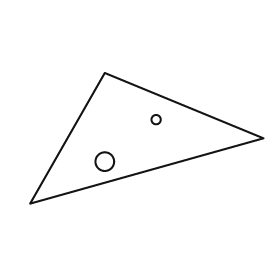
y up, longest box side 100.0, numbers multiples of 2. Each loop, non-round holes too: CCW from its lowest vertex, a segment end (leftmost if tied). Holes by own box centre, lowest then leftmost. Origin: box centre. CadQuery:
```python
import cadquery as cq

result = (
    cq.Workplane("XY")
    .moveTo(-50.0, -28.0)
    .lineTo(50.0, 0.0)
    .lineTo(-18.0, 28.0)
    .close()
    .moveTo(-18.0, -10.0)
    .circle(4.0)
    .moveTo(4.0, 8.0)
    .circle(2.0)
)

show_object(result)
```